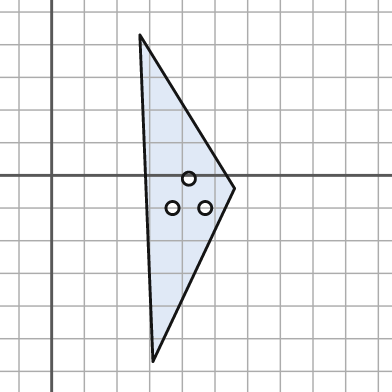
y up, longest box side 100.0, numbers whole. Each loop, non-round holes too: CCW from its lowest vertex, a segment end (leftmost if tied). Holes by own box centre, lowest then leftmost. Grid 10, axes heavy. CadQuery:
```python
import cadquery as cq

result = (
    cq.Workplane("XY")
    .moveTo(31.0, -57.0)
    .lineTo(56.0, -4.0)
    .lineTo(27.0, 43.0)
    .close()
    .moveTo(37.0, -10.0)
    .circle(2.0)
    .moveTo(47.0, -10.0)
    .circle(2.0)
    .moveTo(42.0, -1.0)
    .circle(2.0)
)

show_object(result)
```